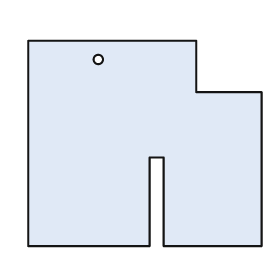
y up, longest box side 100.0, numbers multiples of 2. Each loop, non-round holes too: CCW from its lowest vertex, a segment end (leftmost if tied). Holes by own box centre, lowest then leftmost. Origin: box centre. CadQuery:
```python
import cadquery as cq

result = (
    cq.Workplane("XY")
    .moveTo(-50.0, -44.0)
    .lineTo(2.0, -44.0)
    .lineTo(2.0, -6.0)
    .lineTo(8.0, -6.0)
    .lineTo(8.0, -44.0)
    .lineTo(50.0, -44.0)
    .lineTo(50.0, 22.0)
    .lineTo(22.0, 22.0)
    .lineTo(22.0, 44.0)
    .lineTo(-50.0, 44.0)
    .close()
    .moveTo(-20.0, 36.0)
    .circle(2.0)
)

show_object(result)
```